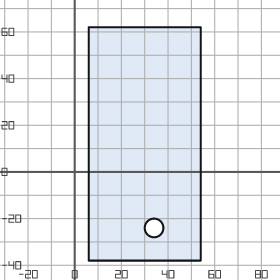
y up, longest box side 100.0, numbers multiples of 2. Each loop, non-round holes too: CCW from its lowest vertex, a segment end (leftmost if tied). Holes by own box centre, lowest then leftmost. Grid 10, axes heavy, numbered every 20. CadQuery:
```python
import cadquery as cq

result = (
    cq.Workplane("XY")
    .moveTo(6.0, -38.0)
    .lineTo(54.0, -38.0)
    .lineTo(54.0, 62.0)
    .lineTo(6.0, 62.0)
    .close()
    .moveTo(34.0, -24.0)
    .circle(4.0)
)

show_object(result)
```